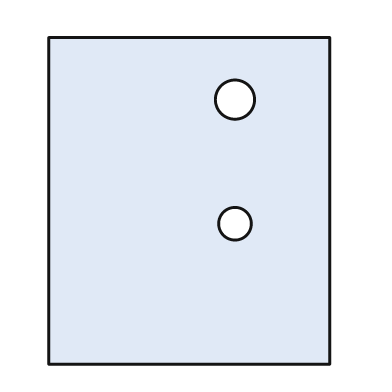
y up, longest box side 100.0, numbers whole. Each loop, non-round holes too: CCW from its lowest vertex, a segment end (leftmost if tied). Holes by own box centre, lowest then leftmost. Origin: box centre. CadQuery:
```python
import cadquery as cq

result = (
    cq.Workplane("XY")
    .moveTo(-43.0, -50.0)
    .lineTo(43.0, -50.0)
    .lineTo(43.0, 50.0)
    .lineTo(-43.0, 50.0)
    .close()
    .moveTo(14.0, -7.0)
    .circle(5.0)
    .moveTo(14.0, 31.0)
    .circle(6.0)
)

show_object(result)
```